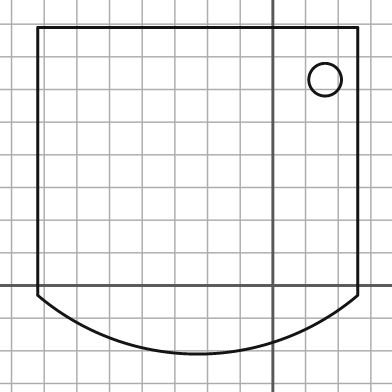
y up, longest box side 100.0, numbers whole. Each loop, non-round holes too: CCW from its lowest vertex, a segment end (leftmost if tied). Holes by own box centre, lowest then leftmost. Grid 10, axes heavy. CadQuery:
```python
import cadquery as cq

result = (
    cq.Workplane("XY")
    .moveTo(-72.0, -3.0)
    .threePointArc((-23.0, -21.0), (26.0, -3.0))
    .lineTo(26.0, 79.0)
    .lineTo(-72.0, 79.0)
    .close()
    .moveTo(16.0, 63.0)
    .circle(5.0)
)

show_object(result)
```